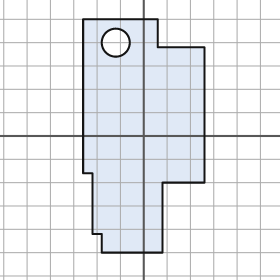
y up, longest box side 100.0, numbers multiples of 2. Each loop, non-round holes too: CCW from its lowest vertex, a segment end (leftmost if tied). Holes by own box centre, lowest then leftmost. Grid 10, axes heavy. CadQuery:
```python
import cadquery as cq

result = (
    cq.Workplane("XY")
    .moveTo(-18.0, -50.0)
    .lineTo(8.0, -50.0)
    .lineTo(8.0, -20.0)
    .lineTo(26.0, -20.0)
    .lineTo(26.0, 38.0)
    .lineTo(6.0, 38.0)
    .lineTo(6.0, 50.0)
    .lineTo(-26.0, 50.0)
    .lineTo(-26.0, -16.0)
    .lineTo(-22.0, -16.0)
    .lineTo(-22.0, -42.0)
    .lineTo(-18.0, -42.0)
    .close()
    .moveTo(-12.0, 40.0)
    .circle(6.0)
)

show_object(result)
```